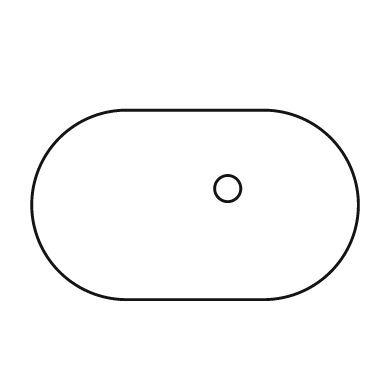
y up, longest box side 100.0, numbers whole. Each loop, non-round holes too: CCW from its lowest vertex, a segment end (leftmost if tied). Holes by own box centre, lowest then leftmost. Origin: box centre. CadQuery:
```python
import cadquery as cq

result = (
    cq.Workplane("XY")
    .moveTo(-21.0, -29.0)
    .lineTo(21.0, -29.0)
    .threePointArc((50.0, 0.0), (21.0, 29.0))
    .lineTo(-21.0, 29.0)
    .threePointArc((-50.0, 0.0), (-21.0, -29.0))
    .close()
    .moveTo(10.0, 5.0)
    .circle(4.0)
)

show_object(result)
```